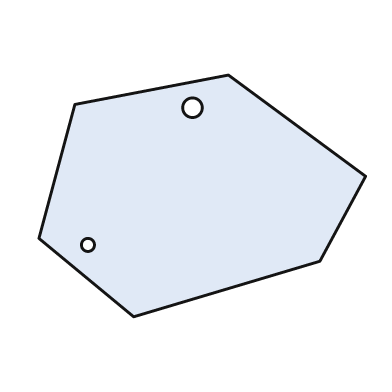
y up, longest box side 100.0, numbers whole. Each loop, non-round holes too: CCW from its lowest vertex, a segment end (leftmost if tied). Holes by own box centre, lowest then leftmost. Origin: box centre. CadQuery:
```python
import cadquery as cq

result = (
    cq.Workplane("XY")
    .moveTo(-21.0, -37.0)
    .lineTo(36.0, -20.0)
    .lineTo(50.0, 6.0)
    .lineTo(8.0, 37.0)
    .lineTo(-39.0, 28.0)
    .lineTo(-50.0, -13.0)
    .close()
    .moveTo(-35.0, -15.0)
    .circle(2.0)
    .moveTo(-3.0, 27.0)
    .circle(3.0)
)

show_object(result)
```